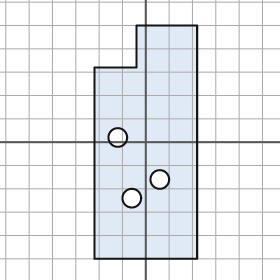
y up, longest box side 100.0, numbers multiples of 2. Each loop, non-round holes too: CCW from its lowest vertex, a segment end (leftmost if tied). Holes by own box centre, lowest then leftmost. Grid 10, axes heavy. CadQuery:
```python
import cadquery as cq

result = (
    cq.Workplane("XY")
    .moveTo(-22.0, -50.0)
    .lineTo(22.0, -50.0)
    .lineTo(22.0, 50.0)
    .lineTo(-4.0, 50.0)
    .lineTo(-4.0, 32.0)
    .lineTo(-22.0, 32.0)
    .close()
    .moveTo(-6.0, -24.0)
    .circle(4.0)
    .moveTo(6.0, -16.0)
    .circle(4.0)
    .moveTo(-12.0, 2.0)
    .circle(4.0)
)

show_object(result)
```